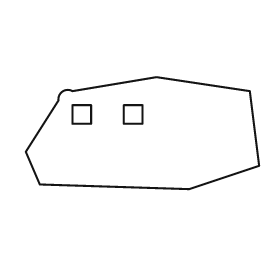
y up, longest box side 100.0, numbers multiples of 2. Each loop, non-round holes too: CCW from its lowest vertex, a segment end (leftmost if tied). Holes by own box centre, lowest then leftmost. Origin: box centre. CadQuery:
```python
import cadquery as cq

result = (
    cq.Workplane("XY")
    .moveTo(20.0, -24.0)
    .lineTo(50.0, -14.0)
    .lineTo(46.0, 18.0)
    .lineTo(6.0, 24.0)
    .lineTo(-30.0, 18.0)
    .threePointArc((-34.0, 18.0), (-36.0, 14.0))
    .lineTo(-50.0, -8.0)
    .lineTo(-44.0, -22.0)
    .close()
    .moveTo(-30.0, 4.0)
    .lineTo(-22.0, 4.0)
    .lineTo(-22.0, 12.0)
    .lineTo(-30.0, 12.0)
    .close()
    .moveTo(-8.0, 4.0)
    .lineTo(0.0, 4.0)
    .lineTo(0.0, 12.0)
    .lineTo(-8.0, 12.0)
    .close()
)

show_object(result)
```